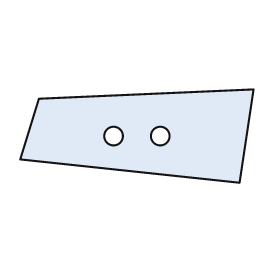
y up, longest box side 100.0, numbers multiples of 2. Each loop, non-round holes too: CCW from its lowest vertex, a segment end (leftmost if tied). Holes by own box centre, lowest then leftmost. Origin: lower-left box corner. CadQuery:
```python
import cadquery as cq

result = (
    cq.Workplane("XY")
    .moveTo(94.0, 0.0)
    .lineTo(100.0, 40.0)
    .lineTo(8.0, 36.0)
    .lineTo(0.0, 10.0)
    .close()
    .moveTo(40.0, 20.0)
    .circle(4.0)
    .moveTo(60.0, 20.0)
    .circle(4.0)
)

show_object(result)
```